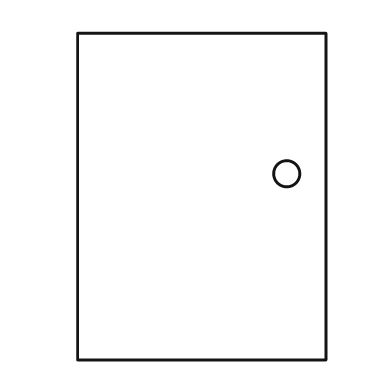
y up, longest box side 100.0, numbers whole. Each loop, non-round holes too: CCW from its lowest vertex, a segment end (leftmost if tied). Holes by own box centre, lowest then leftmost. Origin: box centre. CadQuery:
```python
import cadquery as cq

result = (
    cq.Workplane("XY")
    .moveTo(-38.0, -50.0)
    .lineTo(38.0, -50.0)
    .lineTo(38.0, 50.0)
    .lineTo(-38.0, 50.0)
    .close()
    .moveTo(26.0, 7.0)
    .circle(4.0)
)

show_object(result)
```